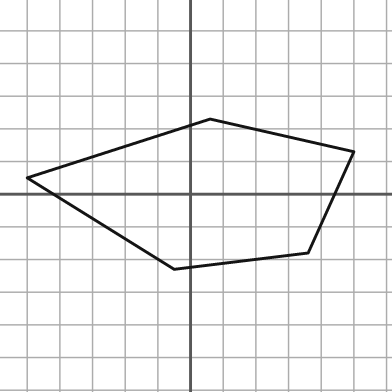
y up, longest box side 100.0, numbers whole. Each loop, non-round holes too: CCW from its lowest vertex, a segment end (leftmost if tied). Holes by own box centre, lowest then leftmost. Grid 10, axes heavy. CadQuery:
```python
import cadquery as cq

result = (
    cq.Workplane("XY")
    .moveTo(-5.0, -23.0)
    .lineTo(36.0, -18.0)
    .lineTo(50.0, 13.0)
    .lineTo(6.0, 23.0)
    .lineTo(-50.0, 5.0)
    .close()
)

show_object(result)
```